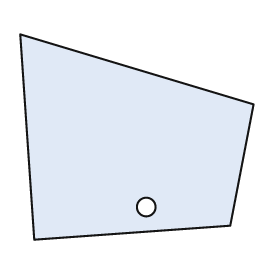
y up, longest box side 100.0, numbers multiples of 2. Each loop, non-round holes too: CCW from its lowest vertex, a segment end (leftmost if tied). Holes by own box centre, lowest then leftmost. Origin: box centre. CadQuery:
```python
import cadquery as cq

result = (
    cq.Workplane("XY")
    .moveTo(-44.0, -44.0)
    .lineTo(40.0, -38.0)
    .lineTo(50.0, 14.0)
    .lineTo(-50.0, 44.0)
    .close()
    .moveTo(4.0, -30.0)
    .circle(4.0)
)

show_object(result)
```